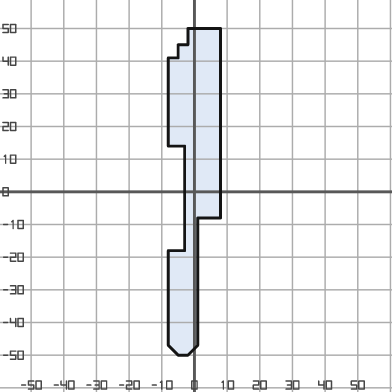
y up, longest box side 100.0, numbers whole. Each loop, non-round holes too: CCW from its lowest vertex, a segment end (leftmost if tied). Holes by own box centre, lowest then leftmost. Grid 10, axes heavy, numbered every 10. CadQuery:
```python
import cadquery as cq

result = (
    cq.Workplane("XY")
    .moveTo(-5.0, -50.0)
    .lineTo(-2.0, -50.0)
    .lineTo(1.0, -47.0)
    .lineTo(1.0, -8.0)
    .lineTo(8.0, -8.0)
    .lineTo(8.0, 50.0)
    .lineTo(-2.0, 50.0)
    .lineTo(-2.0, 45.0)
    .lineTo(-5.0, 45.0)
    .lineTo(-5.0, 41.0)
    .lineTo(-8.0, 41.0)
    .lineTo(-8.0, 14.0)
    .lineTo(-3.0, 14.0)
    .lineTo(-3.0, -18.0)
    .lineTo(-8.0, -18.0)
    .lineTo(-8.0, -47.0)
    .close()
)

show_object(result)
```